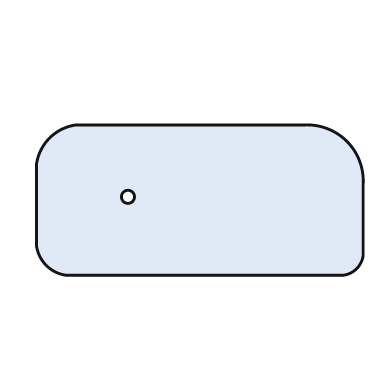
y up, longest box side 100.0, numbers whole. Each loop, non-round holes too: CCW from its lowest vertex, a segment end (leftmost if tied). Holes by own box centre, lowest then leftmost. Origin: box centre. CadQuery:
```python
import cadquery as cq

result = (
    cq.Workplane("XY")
    .moveTo(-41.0, -23.0)
    .lineTo(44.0, -23.0)
    .threePointArc((48.0, -21.0), (50.0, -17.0))
    .lineTo(50.0, 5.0)
    .threePointArc((45.0, 18.0), (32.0, 23.0))
    .lineTo(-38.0, 23.0)
    .threePointArc((-46.0, 19.0), (-50.0, 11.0))
    .lineTo(-50.0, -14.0)
    .threePointArc((-47.0, -20.0), (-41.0, -23.0))
    .close()
    .moveTo(-22.0, 1.0)
    .circle(2.0)
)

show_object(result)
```